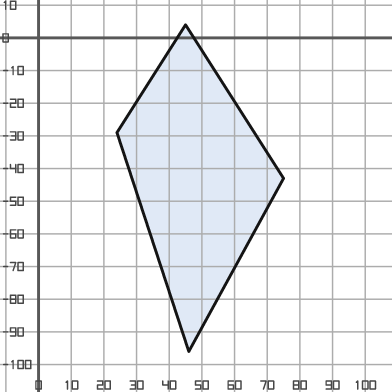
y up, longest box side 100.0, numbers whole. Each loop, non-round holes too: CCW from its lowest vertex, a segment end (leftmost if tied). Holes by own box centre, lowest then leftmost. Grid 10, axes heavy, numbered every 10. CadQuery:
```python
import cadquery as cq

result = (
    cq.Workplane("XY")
    .moveTo(46.0, -96.0)
    .lineTo(75.0, -43.0)
    .lineTo(45.0, 4.0)
    .lineTo(24.0, -29.0)
    .close()
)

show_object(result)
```